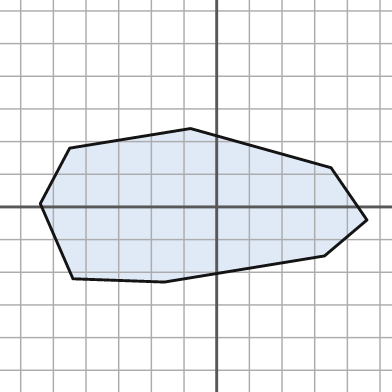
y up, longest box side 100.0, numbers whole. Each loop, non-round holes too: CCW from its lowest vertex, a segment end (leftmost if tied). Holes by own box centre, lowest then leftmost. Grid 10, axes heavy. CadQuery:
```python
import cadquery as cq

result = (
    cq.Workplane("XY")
    .moveTo(-16.0, -23.0)
    .lineTo(33.0, -15.0)
    .lineTo(46.0, -4.0)
    .lineTo(35.0, 12.0)
    .lineTo(-8.0, 24.0)
    .lineTo(-45.0, 18.0)
    .lineTo(-54.0, 1.0)
    .lineTo(-44.0, -22.0)
    .close()
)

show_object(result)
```